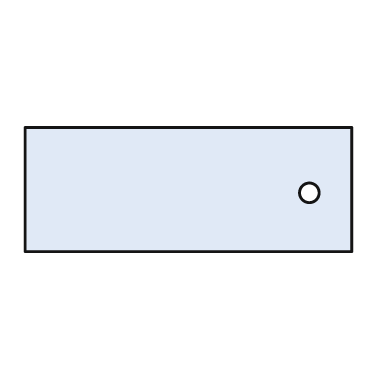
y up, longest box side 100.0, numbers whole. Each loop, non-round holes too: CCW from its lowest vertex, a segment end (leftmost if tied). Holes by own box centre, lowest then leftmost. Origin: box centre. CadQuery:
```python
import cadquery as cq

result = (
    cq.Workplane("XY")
    .moveTo(-50.0, -19.0)
    .lineTo(50.0, -19.0)
    .lineTo(50.0, 19.0)
    .lineTo(-50.0, 19.0)
    .close()
    .moveTo(37.0, -1.0)
    .circle(3.0)
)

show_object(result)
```